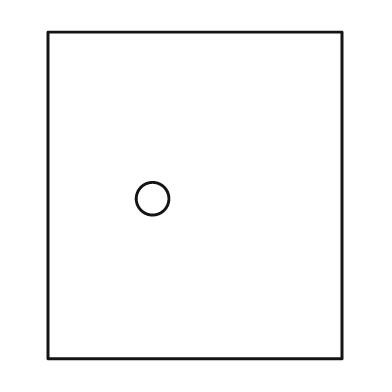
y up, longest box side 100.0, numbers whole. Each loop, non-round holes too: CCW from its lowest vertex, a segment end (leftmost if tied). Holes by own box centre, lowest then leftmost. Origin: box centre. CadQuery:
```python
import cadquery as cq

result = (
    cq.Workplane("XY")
    .moveTo(-45.0, -50.0)
    .lineTo(45.0, -50.0)
    .lineTo(45.0, 50.0)
    .lineTo(-45.0, 50.0)
    .close()
    .moveTo(-13.0, -1.0)
    .circle(5.0)
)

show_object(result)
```